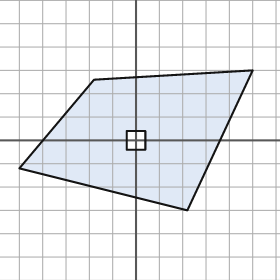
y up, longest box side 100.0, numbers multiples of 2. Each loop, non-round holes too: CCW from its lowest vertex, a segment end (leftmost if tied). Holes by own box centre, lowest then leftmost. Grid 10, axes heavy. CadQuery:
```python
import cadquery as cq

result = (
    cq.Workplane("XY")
    .moveTo(22.0, -30.0)
    .lineTo(50.0, 30.0)
    .lineTo(-18.0, 26.0)
    .lineTo(-50.0, -12.0)
    .close()
    .moveTo(-4.0, -4.0)
    .lineTo(4.0, -4.0)
    .lineTo(4.0, 4.0)
    .lineTo(-4.0, 4.0)
    .close()
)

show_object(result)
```